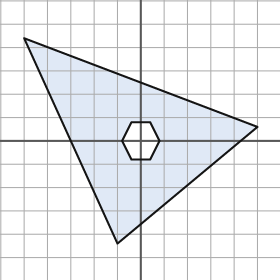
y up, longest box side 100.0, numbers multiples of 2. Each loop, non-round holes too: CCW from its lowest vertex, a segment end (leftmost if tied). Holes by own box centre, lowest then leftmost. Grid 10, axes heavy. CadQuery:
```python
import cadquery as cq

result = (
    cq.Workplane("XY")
    .moveTo(-10.0, -44.0)
    .lineTo(50.0, 6.0)
    .lineTo(-50.0, 44.0)
    .close()
    .moveTo(-4.0, -8.0)
    .lineTo(4.0, -8.0)
    .lineTo(8.0, 0.0)
    .lineTo(4.0, 8.0)
    .lineTo(-4.0, 8.0)
    .lineTo(-8.0, 0.0)
    .close()
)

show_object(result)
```